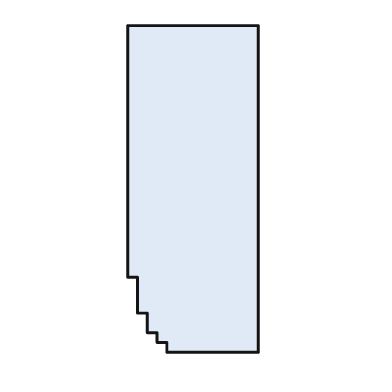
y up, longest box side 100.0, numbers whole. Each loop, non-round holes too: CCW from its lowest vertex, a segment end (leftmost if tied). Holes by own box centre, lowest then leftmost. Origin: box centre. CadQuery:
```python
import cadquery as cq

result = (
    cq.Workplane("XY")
    .moveTo(-8.0, -50.0)
    .lineTo(20.0, -50.0)
    .lineTo(20.0, 50.0)
    .lineTo(-20.0, 50.0)
    .lineTo(-20.0, -27.0)
    .lineTo(-17.0, -27.0)
    .lineTo(-17.0, -38.0)
    .lineTo(-14.0, -38.0)
    .lineTo(-14.0, -44.0)
    .lineTo(-11.0, -44.0)
    .lineTo(-11.0, -47.0)
    .lineTo(-8.0, -47.0)
    .close()
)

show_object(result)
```